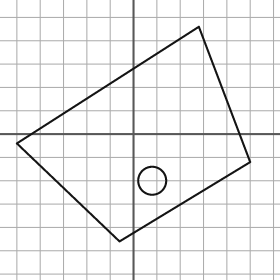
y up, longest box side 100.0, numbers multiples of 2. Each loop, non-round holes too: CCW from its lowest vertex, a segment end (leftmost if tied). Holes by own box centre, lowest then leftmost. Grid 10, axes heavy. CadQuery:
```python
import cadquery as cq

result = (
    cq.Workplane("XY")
    .moveTo(-6.0, -46.0)
    .lineTo(50.0, -12.0)
    .lineTo(28.0, 46.0)
    .lineTo(-50.0, -4.0)
    .close()
    .moveTo(8.0, -20.0)
    .circle(6.0)
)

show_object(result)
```